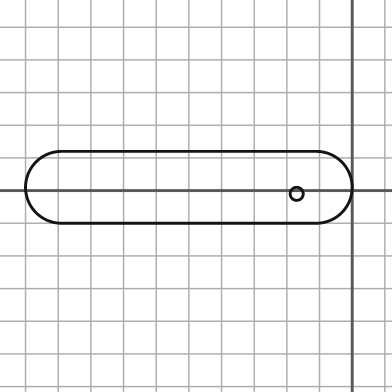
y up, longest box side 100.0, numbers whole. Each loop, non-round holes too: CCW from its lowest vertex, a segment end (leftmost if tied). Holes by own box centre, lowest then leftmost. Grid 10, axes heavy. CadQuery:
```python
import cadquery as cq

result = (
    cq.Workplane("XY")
    .moveTo(-89.0, -10.0)
    .lineTo(-11.0, -10.0)
    .threePointArc((0.0, 1.0), (-11.0, 12.0))
    .lineTo(-89.0, 12.0)
    .threePointArc((-100.0, 1.0), (-89.0, -10.0))
    .close()
    .moveTo(-17.0, -1.0)
    .circle(2.0)
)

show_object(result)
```